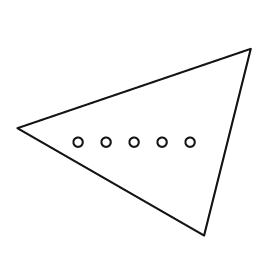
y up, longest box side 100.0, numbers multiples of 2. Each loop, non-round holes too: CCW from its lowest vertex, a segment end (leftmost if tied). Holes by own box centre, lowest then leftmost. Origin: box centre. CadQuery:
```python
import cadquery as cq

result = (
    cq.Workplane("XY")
    .moveTo(30.0, -40.0)
    .lineTo(50.0, 40.0)
    .lineTo(-50.0, 6.0)
    .close()
    .moveTo(-24.0, 0.0)
    .circle(2.0)
    .moveTo(-12.0, 0.0)
    .circle(2.0)
    .moveTo(0.0, 0.0)
    .circle(2.0)
    .moveTo(12.0, 0.0)
    .circle(2.0)
    .moveTo(24.0, 0.0)
    .circle(2.0)
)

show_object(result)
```